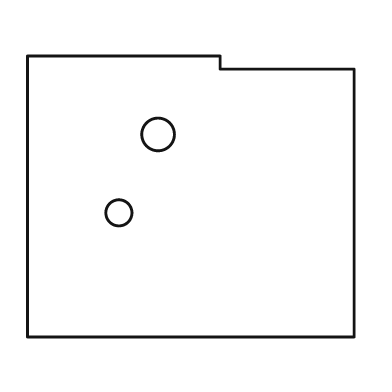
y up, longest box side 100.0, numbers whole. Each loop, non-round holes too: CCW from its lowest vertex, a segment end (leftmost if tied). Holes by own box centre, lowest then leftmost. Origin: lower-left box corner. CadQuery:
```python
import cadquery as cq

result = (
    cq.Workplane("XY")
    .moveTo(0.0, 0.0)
    .lineTo(100.0, 0.0)
    .lineTo(100.0, 82.0)
    .lineTo(59.0, 82.0)
    .lineTo(59.0, 86.0)
    .lineTo(0.0, 86.0)
    .close()
    .moveTo(28.0, 38.0)
    .circle(4.0)
    .moveTo(40.0, 62.0)
    .circle(5.0)
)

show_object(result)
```